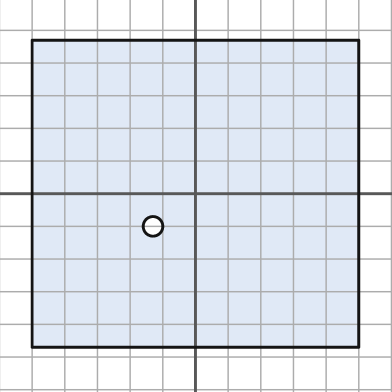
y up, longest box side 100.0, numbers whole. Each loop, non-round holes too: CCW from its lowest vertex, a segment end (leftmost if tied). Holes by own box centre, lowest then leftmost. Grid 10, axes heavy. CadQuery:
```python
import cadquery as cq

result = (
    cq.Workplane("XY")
    .moveTo(-50.0, -47.0)
    .lineTo(50.0, -47.0)
    .lineTo(50.0, 47.0)
    .lineTo(-50.0, 47.0)
    .close()
    .moveTo(-13.0, -10.0)
    .circle(3.0)
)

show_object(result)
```